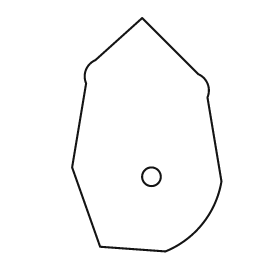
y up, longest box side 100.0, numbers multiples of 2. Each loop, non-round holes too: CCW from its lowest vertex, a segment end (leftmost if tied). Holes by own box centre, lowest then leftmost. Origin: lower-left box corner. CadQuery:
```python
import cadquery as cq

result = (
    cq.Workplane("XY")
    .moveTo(40.0, 0.0)
    .threePointArc((56.0, 12.0), (64.0, 30.0))
    .lineTo(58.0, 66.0)
    .threePointArc((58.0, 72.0), (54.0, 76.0))
    .lineTo(30.0, 100.0)
    .lineTo(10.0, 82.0)
    .threePointArc((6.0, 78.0), (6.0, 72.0))
    .lineTo(0.0, 36.0)
    .lineTo(12.0, 2.0)
    .close()
    .moveTo(34.0, 32.0)
    .circle(4.0)
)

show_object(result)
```